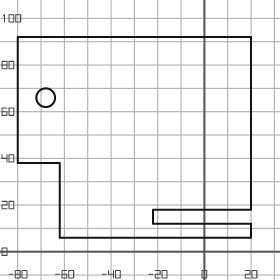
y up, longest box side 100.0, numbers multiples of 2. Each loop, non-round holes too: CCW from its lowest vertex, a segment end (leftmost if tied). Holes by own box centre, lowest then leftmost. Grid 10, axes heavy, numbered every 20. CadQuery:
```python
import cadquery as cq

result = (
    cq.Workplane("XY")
    .moveTo(-62.0, 6.0)
    .lineTo(20.0, 6.0)
    .lineTo(20.0, 12.0)
    .lineTo(-22.0, 12.0)
    .lineTo(-22.0, 18.0)
    .lineTo(20.0, 18.0)
    .lineTo(20.0, 92.0)
    .lineTo(-80.0, 92.0)
    .lineTo(-80.0, 38.0)
    .lineTo(-62.0, 38.0)
    .close()
    .moveTo(-68.0, 66.0)
    .circle(4.0)
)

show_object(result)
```